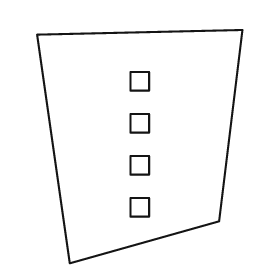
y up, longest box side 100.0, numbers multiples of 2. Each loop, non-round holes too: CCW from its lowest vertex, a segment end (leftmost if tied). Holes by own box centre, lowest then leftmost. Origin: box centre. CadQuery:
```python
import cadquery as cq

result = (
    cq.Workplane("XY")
    .moveTo(-30.0, -50.0)
    .lineTo(34.0, -32.0)
    .lineTo(44.0, 50.0)
    .lineTo(-44.0, 48.0)
    .close()
    .moveTo(-4.0, -30.0)
    .lineTo(4.0, -30.0)
    .lineTo(4.0, -22.0)
    .lineTo(-4.0, -22.0)
    .close()
    .moveTo(-4.0, -12.0)
    .lineTo(4.0, -12.0)
    .lineTo(4.0, -4.0)
    .lineTo(-4.0, -4.0)
    .close()
    .moveTo(-4.0, 6.0)
    .lineTo(4.0, 6.0)
    .lineTo(4.0, 14.0)
    .lineTo(-4.0, 14.0)
    .close()
    .moveTo(-4.0, 24.0)
    .lineTo(4.0, 24.0)
    .lineTo(4.0, 32.0)
    .lineTo(-4.0, 32.0)
    .close()
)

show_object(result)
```